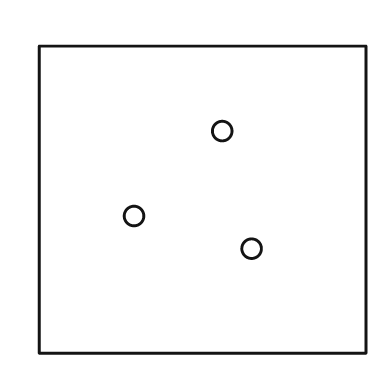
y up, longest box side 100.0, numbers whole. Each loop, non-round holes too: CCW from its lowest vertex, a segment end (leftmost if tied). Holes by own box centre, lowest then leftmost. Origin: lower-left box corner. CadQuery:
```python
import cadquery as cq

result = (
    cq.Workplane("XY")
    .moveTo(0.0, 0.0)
    .lineTo(100.0, 0.0)
    .lineTo(100.0, 94.0)
    .lineTo(0.0, 94.0)
    .close()
    .moveTo(65.0, 32.0)
    .circle(3.0)
    .moveTo(29.0, 42.0)
    .circle(3.0)
    .moveTo(56.0, 68.0)
    .circle(3.0)
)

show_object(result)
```